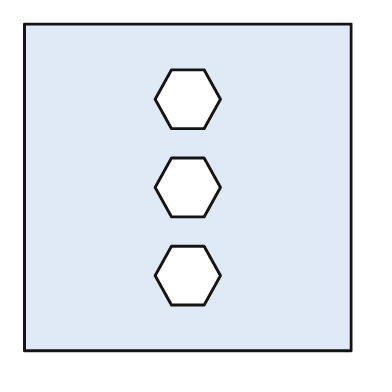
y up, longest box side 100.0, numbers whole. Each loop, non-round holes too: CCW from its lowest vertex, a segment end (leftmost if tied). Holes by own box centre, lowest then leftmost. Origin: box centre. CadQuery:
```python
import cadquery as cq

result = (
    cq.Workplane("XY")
    .moveTo(-50.0, -50.0)
    .lineTo(50.0, -50.0)
    .lineTo(50.0, 50.0)
    .lineTo(-50.0, 50.0)
    .close()
    .moveTo(-5.0, -36.0)
    .lineTo(5.0, -36.0)
    .lineTo(10.0, -27.0)
    .lineTo(5.0, -18.0)
    .lineTo(-5.0, -18.0)
    .lineTo(-10.0, -27.0)
    .close()
    .moveTo(-5.0, -9.0)
    .lineTo(5.0, -9.0)
    .lineTo(10.0, 0.0)
    .lineTo(5.0, 9.0)
    .lineTo(-5.0, 9.0)
    .lineTo(-10.0, 0.0)
    .close()
    .moveTo(-5.0, 18.0)
    .lineTo(5.0, 18.0)
    .lineTo(10.0, 27.0)
    .lineTo(5.0, 36.0)
    .lineTo(-5.0, 36.0)
    .lineTo(-10.0, 27.0)
    .close()
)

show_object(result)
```